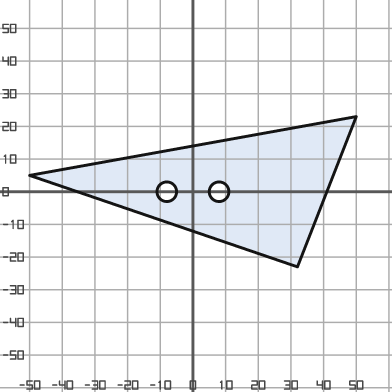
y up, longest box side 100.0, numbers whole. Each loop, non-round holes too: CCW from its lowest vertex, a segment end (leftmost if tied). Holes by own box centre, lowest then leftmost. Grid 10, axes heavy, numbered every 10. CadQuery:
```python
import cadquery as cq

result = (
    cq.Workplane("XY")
    .moveTo(32.0, -23.0)
    .lineTo(50.0, 23.0)
    .lineTo(-50.0, 5.0)
    .close()
    .moveTo(-8.0, 0.0)
    .circle(3.0)
    .moveTo(8.0, 0.0)
    .circle(3.0)
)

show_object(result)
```